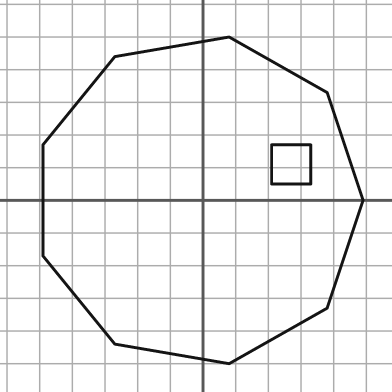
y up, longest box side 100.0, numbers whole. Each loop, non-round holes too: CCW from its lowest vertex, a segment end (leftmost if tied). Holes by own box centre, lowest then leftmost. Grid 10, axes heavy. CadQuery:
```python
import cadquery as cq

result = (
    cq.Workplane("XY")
    .moveTo(8.0, -50.0)
    .lineTo(38.0, -33.0)
    .lineTo(49.0, 0.0)
    .lineTo(38.0, 33.0)
    .lineTo(8.0, 50.0)
    .lineTo(-27.0, 44.0)
    .lineTo(-49.0, 17.0)
    .lineTo(-49.0, -17.0)
    .lineTo(-27.0, -44.0)
    .close()
    .moveTo(21.0, 5.0)
    .lineTo(33.0, 5.0)
    .lineTo(33.0, 17.0)
    .lineTo(21.0, 17.0)
    .close()
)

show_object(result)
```